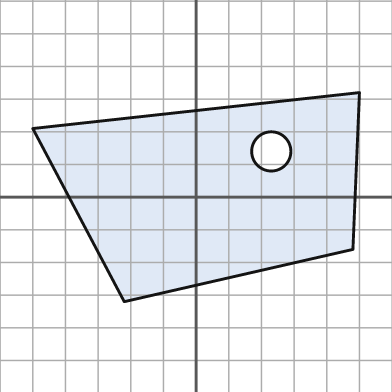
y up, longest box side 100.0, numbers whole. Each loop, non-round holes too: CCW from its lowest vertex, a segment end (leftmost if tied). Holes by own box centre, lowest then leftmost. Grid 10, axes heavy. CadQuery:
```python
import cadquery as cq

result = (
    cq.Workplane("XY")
    .moveTo(-22.0, -32.0)
    .lineTo(48.0, -16.0)
    .lineTo(50.0, 32.0)
    .lineTo(-50.0, 21.0)
    .close()
    .moveTo(23.0, 14.0)
    .circle(6.0)
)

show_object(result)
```